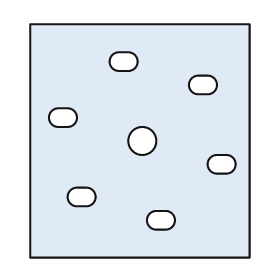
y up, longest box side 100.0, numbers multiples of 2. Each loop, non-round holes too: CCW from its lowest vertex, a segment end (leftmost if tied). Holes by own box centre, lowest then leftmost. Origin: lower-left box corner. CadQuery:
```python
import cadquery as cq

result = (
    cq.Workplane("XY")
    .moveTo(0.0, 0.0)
    .lineTo(94.0, 0.0)
    .lineTo(94.0, 100.0)
    .lineTo(0.0, 100.0)
    .close()
    .moveTo(54.0, 12.0)
    .lineTo(58.0, 12.0)
    .threePointArc((62.0, 16.0), (58.0, 20.0))
    .lineTo(54.0, 20.0)
    .threePointArc((50.0, 16.0), (54.0, 12.0))
    .close()
    .moveTo(20.0, 22.0)
    .lineTo(24.0, 22.0)
    .threePointArc((28.0, 26.0), (24.0, 30.0))
    .lineTo(20.0, 30.0)
    .threePointArc((16.0, 26.0), (20.0, 22.0))
    .close()
    .moveTo(80.0, 36.0)
    .lineTo(84.0, 36.0)
    .threePointArc((88.0, 40.0), (84.0, 44.0))
    .lineTo(80.0, 44.0)
    .threePointArc((76.0, 40.0), (80.0, 36.0))
    .close()
    .moveTo(48.0, 50.0)
    .circle(6.0)
    .moveTo(12.0, 56.0)
    .lineTo(16.0, 56.0)
    .threePointArc((20.0, 60.0), (16.0, 64.0))
    .lineTo(12.0, 64.0)
    .threePointArc((8.0, 60.0), (12.0, 56.0))
    .close()
    .moveTo(72.0, 70.0)
    .lineTo(76.0, 70.0)
    .threePointArc((80.0, 74.0), (76.0, 78.0))
    .lineTo(72.0, 78.0)
    .threePointArc((68.0, 74.0), (72.0, 70.0))
    .close()
    .moveTo(38.0, 80.0)
    .lineTo(42.0, 80.0)
    .threePointArc((46.0, 84.0), (42.0, 88.0))
    .lineTo(38.0, 88.0)
    .threePointArc((34.0, 84.0), (38.0, 80.0))
    .close()
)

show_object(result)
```